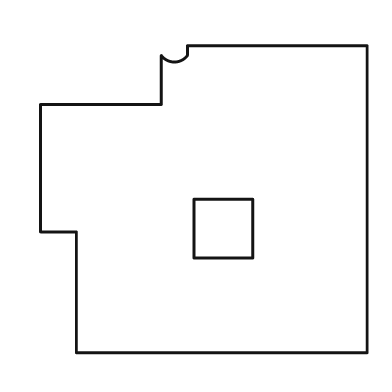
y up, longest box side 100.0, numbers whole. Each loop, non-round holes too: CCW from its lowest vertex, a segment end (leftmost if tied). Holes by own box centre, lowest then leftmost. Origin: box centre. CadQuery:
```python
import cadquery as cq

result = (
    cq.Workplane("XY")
    .moveTo(-39.0, -47.0)
    .lineTo(50.0, -47.0)
    .lineTo(50.0, 47.0)
    .lineTo(-5.0, 47.0)
    .lineTo(-5.0, 44.0)
    .threePointArc((-9.0, 42.0), (-13.0, 44.0))
    .lineTo(-13.0, 29.0)
    .lineTo(-50.0, 29.0)
    .lineTo(-50.0, -10.0)
    .lineTo(-39.0, -10.0)
    .close()
    .moveTo(-3.0, -18.0)
    .lineTo(15.0, -18.0)
    .lineTo(15.0, 0.0)
    .lineTo(-3.0, 0.0)
    .close()
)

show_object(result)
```